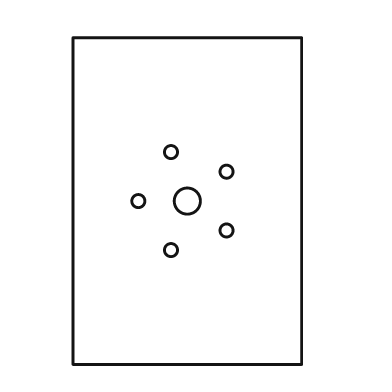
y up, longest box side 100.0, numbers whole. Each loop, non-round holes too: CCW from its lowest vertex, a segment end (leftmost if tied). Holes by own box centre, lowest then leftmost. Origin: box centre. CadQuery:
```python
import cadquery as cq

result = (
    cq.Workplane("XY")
    .moveTo(-35.0, -50.0)
    .lineTo(35.0, -50.0)
    .lineTo(35.0, 50.0)
    .lineTo(-35.0, 50.0)
    .close()
    .moveTo(-5.0, -15.0)
    .circle(2.0)
    .moveTo(12.0, -9.0)
    .circle(2.0)
    .moveTo(-15.0, 0.0)
    .circle(2.0)
    .moveTo(0.0, 0.0)
    .circle(4.0)
    .moveTo(12.0, 9.0)
    .circle(2.0)
    .moveTo(-5.0, 15.0)
    .circle(2.0)
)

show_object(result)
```